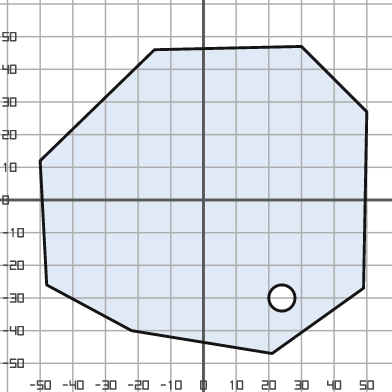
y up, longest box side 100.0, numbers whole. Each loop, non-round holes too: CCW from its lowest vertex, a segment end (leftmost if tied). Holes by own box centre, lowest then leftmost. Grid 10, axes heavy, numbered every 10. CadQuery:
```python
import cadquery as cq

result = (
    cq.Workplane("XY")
    .moveTo(21.0, -47.0)
    .lineTo(49.0, -27.0)
    .lineTo(50.0, 27.0)
    .lineTo(30.0, 47.0)
    .lineTo(-15.0, 46.0)
    .lineTo(-50.0, 12.0)
    .lineTo(-48.0, -26.0)
    .lineTo(-22.0, -40.0)
    .close()
    .moveTo(24.0, -30.0)
    .circle(4.0)
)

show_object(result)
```